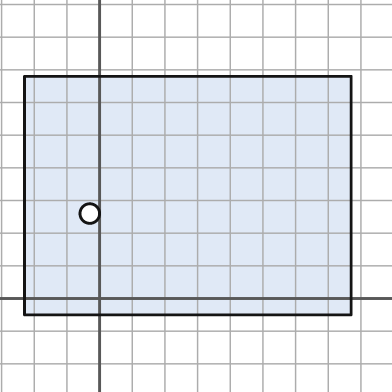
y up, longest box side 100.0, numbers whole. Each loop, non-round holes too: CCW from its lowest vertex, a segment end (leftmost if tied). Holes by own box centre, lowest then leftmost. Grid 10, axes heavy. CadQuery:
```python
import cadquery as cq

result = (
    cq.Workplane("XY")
    .moveTo(-23.0, -5.0)
    .lineTo(77.0, -5.0)
    .lineTo(77.0, 68.0)
    .lineTo(-23.0, 68.0)
    .close()
    .moveTo(-3.0, 26.0)
    .circle(3.0)
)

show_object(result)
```